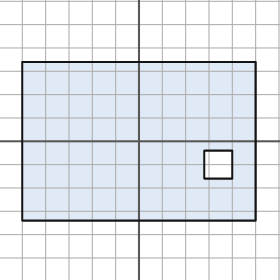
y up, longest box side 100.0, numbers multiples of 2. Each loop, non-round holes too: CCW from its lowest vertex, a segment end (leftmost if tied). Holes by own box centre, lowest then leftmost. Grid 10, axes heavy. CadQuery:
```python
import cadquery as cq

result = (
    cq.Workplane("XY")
    .moveTo(-50.0, -34.0)
    .lineTo(50.0, -34.0)
    .lineTo(50.0, 34.0)
    .lineTo(-50.0, 34.0)
    .close()
    .moveTo(28.0, -16.0)
    .lineTo(40.0, -16.0)
    .lineTo(40.0, -4.0)
    .lineTo(28.0, -4.0)
    .close()
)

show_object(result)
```